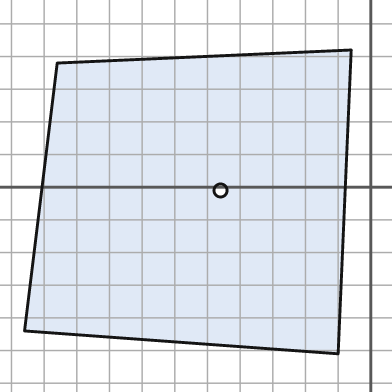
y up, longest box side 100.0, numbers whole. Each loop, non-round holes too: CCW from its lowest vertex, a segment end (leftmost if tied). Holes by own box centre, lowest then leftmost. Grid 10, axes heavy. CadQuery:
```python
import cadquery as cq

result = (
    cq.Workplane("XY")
    .moveTo(-10.0, -51.0)
    .lineTo(-6.0, 42.0)
    .lineTo(-96.0, 38.0)
    .lineTo(-106.0, -44.0)
    .close()
    .moveTo(-46.0, -1.0)
    .circle(2.0)
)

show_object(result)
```